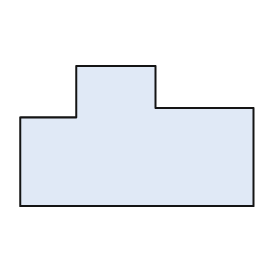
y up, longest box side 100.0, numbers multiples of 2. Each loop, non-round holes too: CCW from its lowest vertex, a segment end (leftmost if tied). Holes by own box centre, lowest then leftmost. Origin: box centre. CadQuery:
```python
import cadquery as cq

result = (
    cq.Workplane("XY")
    .moveTo(-50.0, -30.0)
    .lineTo(50.0, -30.0)
    .lineTo(50.0, 12.0)
    .lineTo(8.0, 12.0)
    .lineTo(8.0, 30.0)
    .lineTo(-26.0, 30.0)
    .lineTo(-26.0, 8.0)
    .lineTo(-50.0, 8.0)
    .close()
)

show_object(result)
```